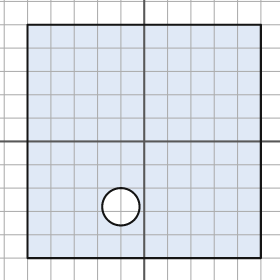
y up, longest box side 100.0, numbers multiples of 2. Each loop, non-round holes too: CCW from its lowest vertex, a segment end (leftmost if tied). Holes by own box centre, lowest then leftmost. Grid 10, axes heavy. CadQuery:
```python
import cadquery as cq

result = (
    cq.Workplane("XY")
    .moveTo(-50.0, -50.0)
    .lineTo(50.0, -50.0)
    .lineTo(50.0, 50.0)
    .lineTo(-50.0, 50.0)
    .close()
    .moveTo(-10.0, -28.0)
    .circle(8.0)
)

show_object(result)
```